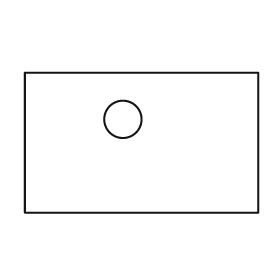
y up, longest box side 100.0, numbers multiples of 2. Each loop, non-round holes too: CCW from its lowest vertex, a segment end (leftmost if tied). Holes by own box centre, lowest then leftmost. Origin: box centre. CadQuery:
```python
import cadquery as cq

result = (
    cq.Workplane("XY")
    .moveTo(-50.0, -30.0)
    .lineTo(50.0, -30.0)
    .lineTo(50.0, 30.0)
    .lineTo(-50.0, 30.0)
    .close()
    .moveTo(-8.0, 10.0)
    .circle(8.0)
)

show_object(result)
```